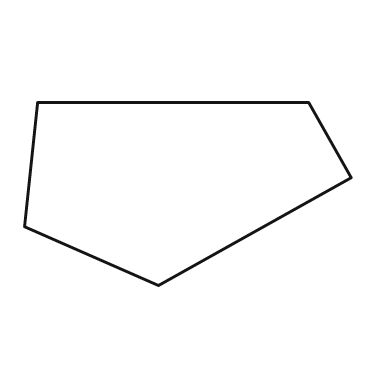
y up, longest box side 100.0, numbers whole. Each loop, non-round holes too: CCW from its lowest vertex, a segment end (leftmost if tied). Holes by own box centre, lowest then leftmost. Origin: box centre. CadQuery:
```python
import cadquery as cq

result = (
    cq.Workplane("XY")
    .moveTo(-9.0, -28.0)
    .lineTo(50.0, 5.0)
    .lineTo(37.0, 28.0)
    .lineTo(-46.0, 28.0)
    .lineTo(-50.0, -10.0)
    .close()
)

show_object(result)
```